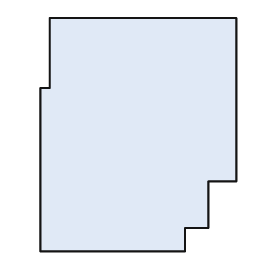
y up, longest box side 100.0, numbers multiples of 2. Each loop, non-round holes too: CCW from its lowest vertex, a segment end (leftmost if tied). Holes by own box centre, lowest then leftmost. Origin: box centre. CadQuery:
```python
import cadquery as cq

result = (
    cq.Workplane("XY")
    .moveTo(-42.0, -50.0)
    .lineTo(20.0, -50.0)
    .lineTo(20.0, -40.0)
    .lineTo(30.0, -40.0)
    .lineTo(30.0, -20.0)
    .lineTo(42.0, -20.0)
    .lineTo(42.0, 50.0)
    .lineTo(-38.0, 50.0)
    .lineTo(-38.0, 20.0)
    .lineTo(-42.0, 20.0)
    .close()
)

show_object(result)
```